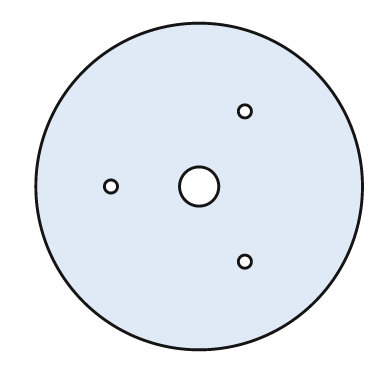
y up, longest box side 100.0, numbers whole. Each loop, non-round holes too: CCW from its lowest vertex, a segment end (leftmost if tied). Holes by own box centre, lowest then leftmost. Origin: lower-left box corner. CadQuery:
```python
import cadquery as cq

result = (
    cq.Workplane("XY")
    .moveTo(50.0, 50.0)
    .circle(50.0)
    .moveTo(64.0, 27.0)
    .circle(2.0)
    .moveTo(23.0, 50.0)
    .circle(2.0)
    .moveTo(50.0, 50.0)
    .circle(6.0)
    .moveTo(64.0, 73.0)
    .circle(2.0)
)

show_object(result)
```